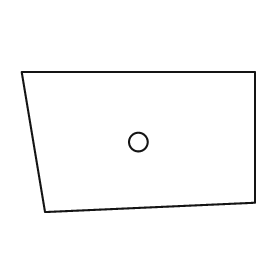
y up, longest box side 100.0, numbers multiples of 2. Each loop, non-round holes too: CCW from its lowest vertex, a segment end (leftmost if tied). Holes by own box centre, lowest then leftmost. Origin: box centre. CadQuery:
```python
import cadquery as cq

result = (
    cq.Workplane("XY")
    .moveTo(-40.0, -30.0)
    .lineTo(50.0, -26.0)
    .lineTo(50.0, 30.0)
    .lineTo(-50.0, 30.0)
    .close()
    .moveTo(0.0, 0.0)
    .circle(4.0)
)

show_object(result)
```